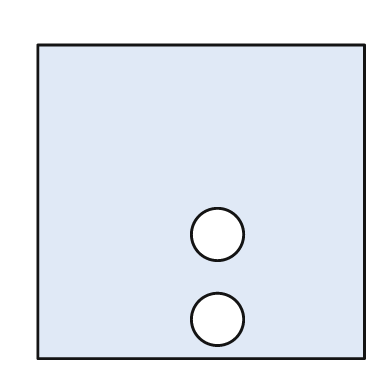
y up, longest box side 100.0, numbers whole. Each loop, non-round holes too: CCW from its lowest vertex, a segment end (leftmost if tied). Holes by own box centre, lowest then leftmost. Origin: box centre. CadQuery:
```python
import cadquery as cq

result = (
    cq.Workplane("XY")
    .moveTo(-50.0, -48.0)
    .lineTo(50.0, -48.0)
    .lineTo(50.0, 48.0)
    .lineTo(-50.0, 48.0)
    .close()
    .moveTo(5.0, -36.0)
    .circle(8.0)
    .moveTo(5.0, -10.0)
    .circle(8.0)
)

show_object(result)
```